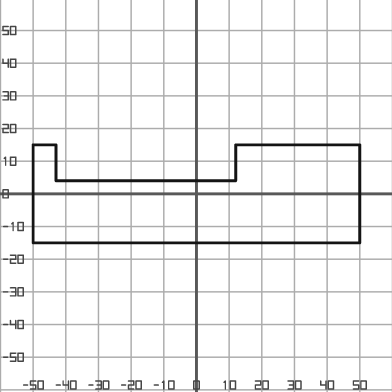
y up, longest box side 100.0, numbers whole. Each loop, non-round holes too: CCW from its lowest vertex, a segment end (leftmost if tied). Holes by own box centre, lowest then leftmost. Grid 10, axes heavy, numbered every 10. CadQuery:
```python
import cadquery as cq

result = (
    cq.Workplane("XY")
    .moveTo(-50.0, -15.0)
    .lineTo(50.0, -15.0)
    .lineTo(50.0, 15.0)
    .lineTo(12.0, 15.0)
    .lineTo(12.0, 4.0)
    .lineTo(-43.0, 4.0)
    .lineTo(-43.0, 15.0)
    .lineTo(-50.0, 15.0)
    .close()
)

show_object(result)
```